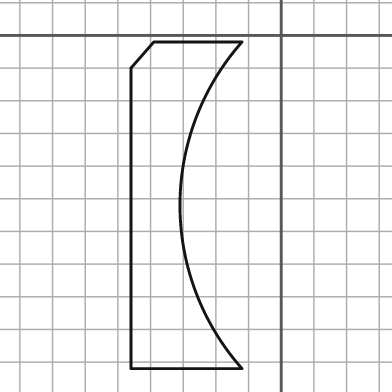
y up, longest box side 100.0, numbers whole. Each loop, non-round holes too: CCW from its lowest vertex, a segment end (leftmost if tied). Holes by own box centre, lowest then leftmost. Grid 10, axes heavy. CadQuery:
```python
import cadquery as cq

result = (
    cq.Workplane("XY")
    .moveTo(-46.0, -102.0)
    .lineTo(-12.0, -102.0)
    .threePointArc((-31.0, -52.0), (-12.0, -2.0))
    .lineTo(-39.0, -2.0)
    .lineTo(-46.0, -10.0)
    .close()
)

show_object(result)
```